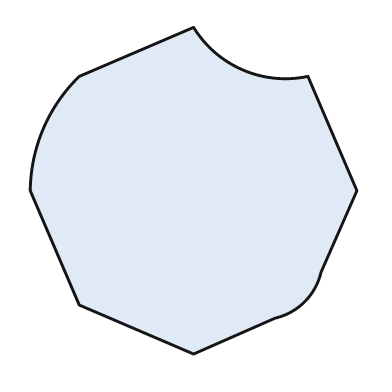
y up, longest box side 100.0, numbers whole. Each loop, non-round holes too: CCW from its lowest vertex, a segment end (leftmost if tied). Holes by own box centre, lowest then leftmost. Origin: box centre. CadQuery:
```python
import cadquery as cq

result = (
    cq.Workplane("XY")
    .moveTo(0.0, -50.0)
    .lineTo(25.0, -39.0)
    .threePointArc((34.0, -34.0), (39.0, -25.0))
    .lineTo(50.0, 0.0)
    .lineTo(35.0, 35.0)
    .threePointArc((15.0, 37.0), (0.0, 50.0))
    .lineTo(-35.0, 35.0)
    .threePointArc((-46.0, 19.0), (-50.0, 0.0))
    .lineTo(-35.0, -35.0)
    .close()
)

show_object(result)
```